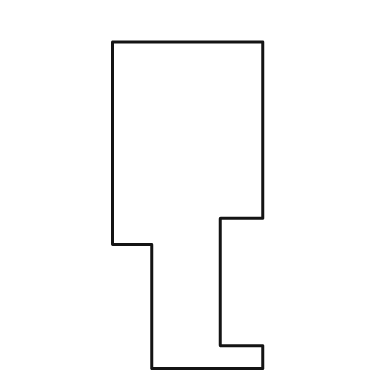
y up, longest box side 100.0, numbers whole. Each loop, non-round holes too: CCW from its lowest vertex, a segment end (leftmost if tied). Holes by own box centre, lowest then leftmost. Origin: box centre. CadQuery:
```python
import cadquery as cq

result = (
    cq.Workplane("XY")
    .moveTo(-11.0, -50.0)
    .lineTo(23.0, -50.0)
    .lineTo(23.0, -43.0)
    .lineTo(10.0, -43.0)
    .lineTo(10.0, -4.0)
    .lineTo(23.0, -4.0)
    .lineTo(23.0, 50.0)
    .lineTo(-23.0, 50.0)
    .lineTo(-23.0, -12.0)
    .lineTo(-11.0, -12.0)
    .close()
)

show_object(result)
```